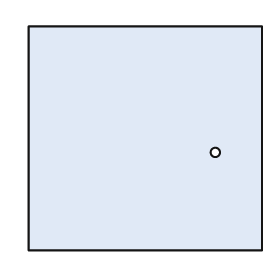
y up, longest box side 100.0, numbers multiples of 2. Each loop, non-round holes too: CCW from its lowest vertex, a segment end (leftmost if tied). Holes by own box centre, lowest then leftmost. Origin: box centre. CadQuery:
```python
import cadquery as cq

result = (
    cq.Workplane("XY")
    .moveTo(-50.0, -48.0)
    .lineTo(50.0, -48.0)
    .lineTo(50.0, 48.0)
    .lineTo(-50.0, 48.0)
    .close()
    .moveTo(30.0, -6.0)
    .circle(2.0)
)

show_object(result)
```